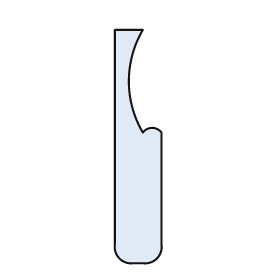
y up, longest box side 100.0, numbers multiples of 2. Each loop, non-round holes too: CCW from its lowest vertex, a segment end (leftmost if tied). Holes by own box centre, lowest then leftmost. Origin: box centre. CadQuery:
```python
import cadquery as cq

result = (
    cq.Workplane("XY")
    .moveTo(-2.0, -50.0)
    .lineTo(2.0, -50.0)
    .threePointArc((8.0, -48.0), (10.0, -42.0))
    .lineTo(10.0, 6.0)
    .threePointArc((6.0, 8.0), (2.0, 6.0))
    .threePointArc((-4.0, 28.0), (2.0, 50.0))
    .lineTo(-10.0, 50.0)
    .lineTo(-10.0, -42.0)
    .threePointArc((-8.0, -48.0), (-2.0, -50.0))
    .close()
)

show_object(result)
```